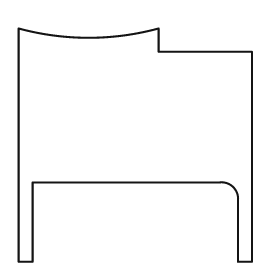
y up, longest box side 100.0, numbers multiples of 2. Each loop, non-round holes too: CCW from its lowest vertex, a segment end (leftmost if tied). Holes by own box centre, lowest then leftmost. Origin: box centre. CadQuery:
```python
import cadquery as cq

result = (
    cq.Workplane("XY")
    .moveTo(-50.0, -50.0)
    .lineTo(-44.0, -50.0)
    .lineTo(-44.0, -16.0)
    .lineTo(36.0, -16.0)
    .threePointArc((42.0, -18.0), (44.0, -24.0))
    .lineTo(44.0, -50.0)
    .lineTo(50.0, -50.0)
    .lineTo(50.0, 40.0)
    .lineTo(10.0, 40.0)
    .lineTo(10.0, 50.0)
    .threePointArc((-20.0, 46.0), (-50.0, 50.0))
    .close()
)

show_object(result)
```